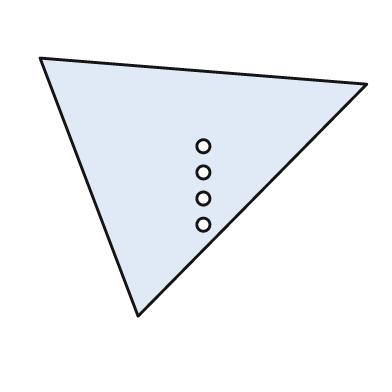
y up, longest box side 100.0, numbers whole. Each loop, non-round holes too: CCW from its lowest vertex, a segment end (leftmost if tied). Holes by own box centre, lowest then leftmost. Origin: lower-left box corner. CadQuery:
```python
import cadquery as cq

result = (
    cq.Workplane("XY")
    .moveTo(30.0, 0.0)
    .lineTo(100.0, 71.0)
    .lineTo(0.0, 79.0)
    .close()
    .moveTo(50.0, 28.0)
    .circle(2.0)
    .moveTo(50.0, 36.0)
    .circle(2.0)
    .moveTo(50.0, 44.0)
    .circle(2.0)
    .moveTo(50.0, 52.0)
    .circle(2.0)
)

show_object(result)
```